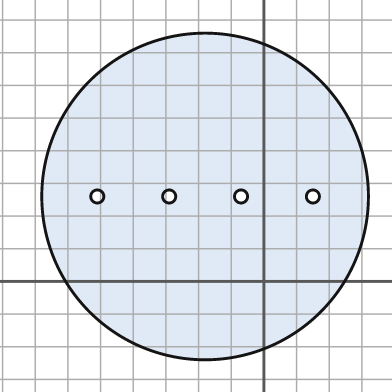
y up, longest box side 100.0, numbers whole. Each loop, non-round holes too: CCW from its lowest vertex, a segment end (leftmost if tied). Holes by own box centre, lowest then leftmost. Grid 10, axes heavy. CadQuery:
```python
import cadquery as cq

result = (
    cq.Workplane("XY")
    .moveTo(-18.0, 26.0)
    .circle(50.0)
    .moveTo(-51.0, 26.0)
    .circle(2.0)
    .moveTo(-29.0, 26.0)
    .circle(2.0)
    .moveTo(-7.0, 26.0)
    .circle(2.0)
    .moveTo(15.0, 26.0)
    .circle(2.0)
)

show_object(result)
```